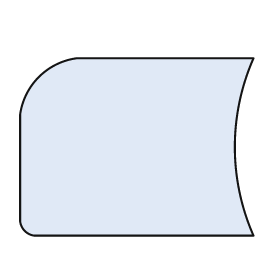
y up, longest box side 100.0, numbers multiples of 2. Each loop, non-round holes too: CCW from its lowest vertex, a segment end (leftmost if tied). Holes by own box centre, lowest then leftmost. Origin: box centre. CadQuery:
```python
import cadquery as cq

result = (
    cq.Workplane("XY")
    .moveTo(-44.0, -38.0)
    .lineTo(50.0, -38.0)
    .threePointArc((42.0, 0.0), (50.0, 38.0))
    .lineTo(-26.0, 38.0)
    .threePointArc((-42.0, 30.0), (-50.0, 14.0))
    .lineTo(-50.0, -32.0)
    .threePointArc((-48.0, -36.0), (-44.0, -38.0))
    .close()
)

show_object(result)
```